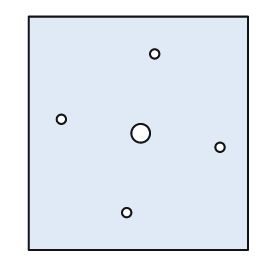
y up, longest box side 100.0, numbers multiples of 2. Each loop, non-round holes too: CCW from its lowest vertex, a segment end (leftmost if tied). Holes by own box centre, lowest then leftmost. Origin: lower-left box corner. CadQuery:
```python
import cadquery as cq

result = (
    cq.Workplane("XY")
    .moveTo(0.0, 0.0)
    .lineTo(94.0, 0.0)
    .lineTo(94.0, 100.0)
    .lineTo(0.0, 100.0)
    .close()
    .moveTo(42.0, 16.0)
    .circle(2.0)
    .moveTo(82.0, 44.0)
    .circle(2.0)
    .moveTo(48.0, 50.0)
    .circle(4.0)
    .moveTo(14.0, 56.0)
    .circle(2.0)
    .moveTo(54.0, 84.0)
    .circle(2.0)
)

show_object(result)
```